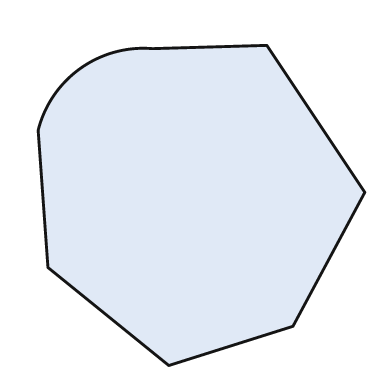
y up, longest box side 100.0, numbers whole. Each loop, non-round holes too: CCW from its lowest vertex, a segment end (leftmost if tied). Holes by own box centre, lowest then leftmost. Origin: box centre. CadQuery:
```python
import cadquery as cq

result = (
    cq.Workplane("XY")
    .moveTo(-10.0, -49.0)
    .lineTo(28.0, -37.0)
    .lineTo(50.0, 4.0)
    .lineTo(20.0, 49.0)
    .lineTo(-15.0, 48.0)
    .threePointArc((-37.0, 42.0), (-50.0, 23.0))
    .lineTo(-47.0, -19.0)
    .close()
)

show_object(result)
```